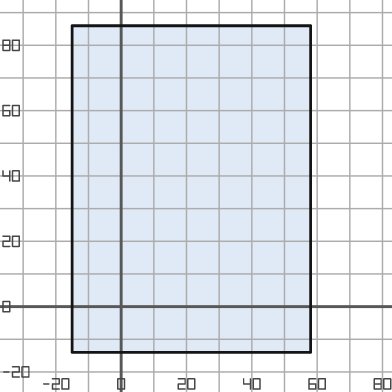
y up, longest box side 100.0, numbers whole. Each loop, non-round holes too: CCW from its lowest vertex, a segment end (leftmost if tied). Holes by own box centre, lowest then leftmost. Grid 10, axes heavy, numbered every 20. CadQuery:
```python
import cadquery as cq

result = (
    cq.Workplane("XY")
    .moveTo(-15.0, -14.0)
    .lineTo(58.0, -14.0)
    .lineTo(58.0, 86.0)
    .lineTo(-15.0, 86.0)
    .close()
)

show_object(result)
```